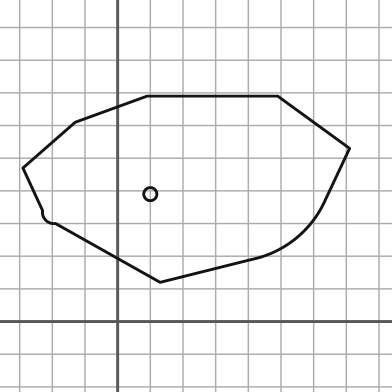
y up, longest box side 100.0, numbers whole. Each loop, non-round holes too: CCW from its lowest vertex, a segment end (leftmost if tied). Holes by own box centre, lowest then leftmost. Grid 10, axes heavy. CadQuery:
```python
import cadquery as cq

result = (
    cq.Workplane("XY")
    .moveTo(13.0, 12.0)
    .lineTo(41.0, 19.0)
    .threePointArc((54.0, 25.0), (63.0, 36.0))
    .lineTo(71.0, 53.0)
    .lineTo(49.0, 69.0)
    .lineTo(9.0, 69.0)
    .lineTo(-13.0, 61.0)
    .lineTo(-29.0, 47.0)
    .lineTo(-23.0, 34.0)
    .threePointArc((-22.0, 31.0), (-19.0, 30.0))
    .close()
    .moveTo(10.0, 39.0)
    .circle(2.0)
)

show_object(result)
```